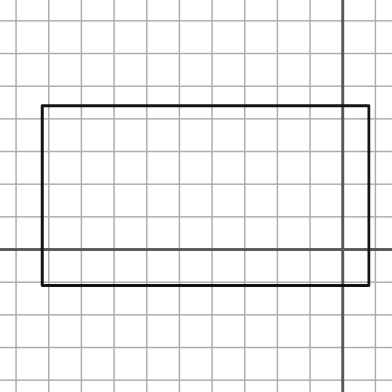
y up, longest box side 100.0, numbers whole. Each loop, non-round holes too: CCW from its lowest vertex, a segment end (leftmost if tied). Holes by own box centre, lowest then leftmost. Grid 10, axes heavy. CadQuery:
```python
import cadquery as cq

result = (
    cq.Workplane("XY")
    .moveTo(-92.0, -11.0)
    .lineTo(8.0, -11.0)
    .lineTo(8.0, 44.0)
    .lineTo(-92.0, 44.0)
    .close()
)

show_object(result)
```